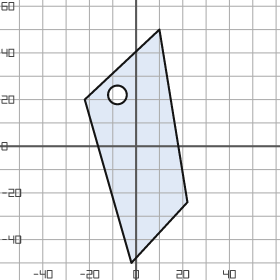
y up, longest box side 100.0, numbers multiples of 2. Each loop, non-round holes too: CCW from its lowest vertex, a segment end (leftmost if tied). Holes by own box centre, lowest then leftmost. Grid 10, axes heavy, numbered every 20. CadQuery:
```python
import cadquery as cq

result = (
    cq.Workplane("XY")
    .moveTo(-2.0, -50.0)
    .lineTo(22.0, -24.0)
    .lineTo(10.0, 50.0)
    .lineTo(-22.0, 20.0)
    .close()
    .moveTo(-8.0, 22.0)
    .circle(4.0)
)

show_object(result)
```